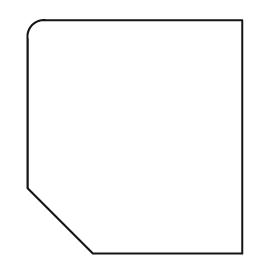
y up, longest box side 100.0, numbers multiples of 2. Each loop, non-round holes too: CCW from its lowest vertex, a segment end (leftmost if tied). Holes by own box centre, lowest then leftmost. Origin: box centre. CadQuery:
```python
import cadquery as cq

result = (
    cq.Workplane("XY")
    .moveTo(-18.0, -50.0)
    .lineTo(46.0, -50.0)
    .lineTo(46.0, 50.0)
    .lineTo(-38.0, 50.0)
    .threePointArc((-44.0, 48.0), (-46.0, 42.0))
    .lineTo(-46.0, -22.0)
    .close()
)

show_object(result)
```